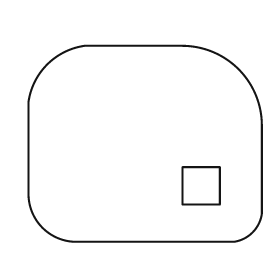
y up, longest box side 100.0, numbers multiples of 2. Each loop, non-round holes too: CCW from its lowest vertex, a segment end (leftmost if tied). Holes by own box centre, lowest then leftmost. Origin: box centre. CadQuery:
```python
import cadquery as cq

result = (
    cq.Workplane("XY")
    .moveTo(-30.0, -42.0)
    .lineTo(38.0, -42.0)
    .threePointArc((46.0, -38.0), (50.0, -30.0))
    .lineTo(50.0, 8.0)
    .threePointArc((40.0, 32.0), (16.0, 42.0))
    .lineTo(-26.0, 42.0)
    .threePointArc((-42.0, 34.0), (-50.0, 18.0))
    .lineTo(-50.0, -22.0)
    .threePointArc((-44.0, -36.0), (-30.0, -42.0))
    .close()
    .moveTo(16.0, -26.0)
    .lineTo(32.0, -26.0)
    .lineTo(32.0, -10.0)
    .lineTo(16.0, -10.0)
    .close()
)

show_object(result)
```